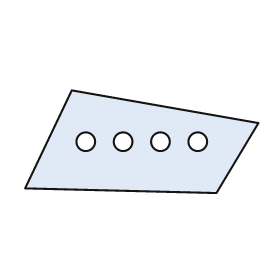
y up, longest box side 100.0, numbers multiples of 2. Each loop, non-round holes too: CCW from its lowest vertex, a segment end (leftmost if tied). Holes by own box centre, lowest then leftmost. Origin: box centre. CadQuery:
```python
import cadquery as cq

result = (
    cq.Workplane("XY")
    .moveTo(32.0, -22.0)
    .lineTo(50.0, 8.0)
    .lineTo(-30.0, 22.0)
    .lineTo(-50.0, -20.0)
    .close()
    .moveTo(-24.0, 0.0)
    .circle(4.0)
    .moveTo(-8.0, 0.0)
    .circle(4.0)
    .moveTo(8.0, 0.0)
    .circle(4.0)
    .moveTo(24.0, 0.0)
    .circle(4.0)
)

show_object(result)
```